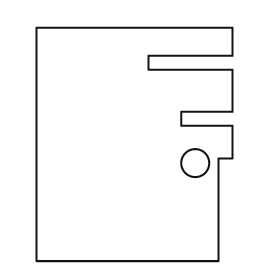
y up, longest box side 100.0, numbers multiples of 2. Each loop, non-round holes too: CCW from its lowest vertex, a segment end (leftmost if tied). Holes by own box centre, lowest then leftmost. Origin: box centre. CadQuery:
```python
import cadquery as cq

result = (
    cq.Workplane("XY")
    .moveTo(-42.0, -50.0)
    .lineTo(36.0, -50.0)
    .lineTo(36.0, -6.0)
    .lineTo(42.0, -6.0)
    .lineTo(42.0, 8.0)
    .lineTo(20.0, 8.0)
    .lineTo(20.0, 14.0)
    .lineTo(42.0, 14.0)
    .lineTo(42.0, 32.0)
    .lineTo(6.0, 32.0)
    .lineTo(6.0, 38.0)
    .lineTo(42.0, 38.0)
    .lineTo(42.0, 50.0)
    .lineTo(-42.0, 50.0)
    .close()
    .moveTo(26.0, -8.0)
    .circle(6.0)
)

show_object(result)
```